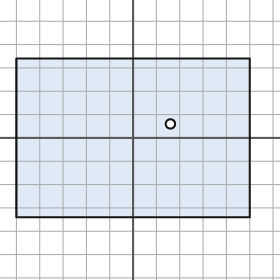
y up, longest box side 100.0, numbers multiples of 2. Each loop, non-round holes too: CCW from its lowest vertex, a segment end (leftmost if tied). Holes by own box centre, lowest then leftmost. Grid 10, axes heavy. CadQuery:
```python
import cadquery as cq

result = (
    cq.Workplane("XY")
    .moveTo(-50.0, -34.0)
    .lineTo(50.0, -34.0)
    .lineTo(50.0, 34.0)
    .lineTo(-50.0, 34.0)
    .close()
    .moveTo(16.0, 6.0)
    .circle(2.0)
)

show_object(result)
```